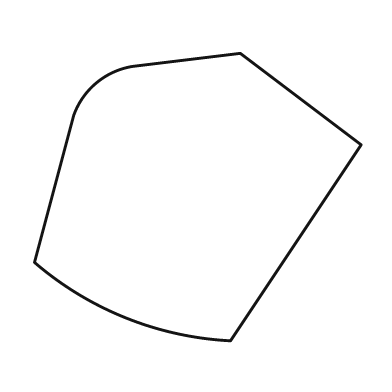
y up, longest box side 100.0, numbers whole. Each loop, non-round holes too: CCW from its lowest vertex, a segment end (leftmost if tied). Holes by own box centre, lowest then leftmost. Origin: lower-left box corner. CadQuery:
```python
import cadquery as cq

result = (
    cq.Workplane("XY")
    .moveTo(60.0, 0.0)
    .lineTo(100.0, 60.0)
    .lineTo(63.0, 88.0)
    .lineTo(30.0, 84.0)
    .threePointArc((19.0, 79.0), (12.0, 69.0))
    .lineTo(0.0, 24.0)
    .threePointArc((28.0, 7.0), (60.0, 0.0))
    .close()
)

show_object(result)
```